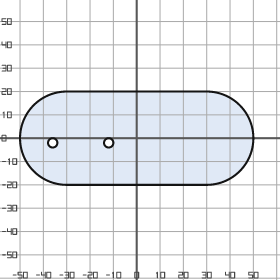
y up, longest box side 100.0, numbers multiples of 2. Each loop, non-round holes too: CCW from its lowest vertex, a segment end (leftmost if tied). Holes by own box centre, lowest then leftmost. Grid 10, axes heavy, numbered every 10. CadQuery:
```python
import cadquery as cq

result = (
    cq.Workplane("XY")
    .moveTo(-30.0, -20.0)
    .lineTo(30.0, -20.0)
    .threePointArc((50.0, 0.0), (30.0, 20.0))
    .lineTo(-30.0, 20.0)
    .threePointArc((-50.0, 0.0), (-30.0, -20.0))
    .close()
    .moveTo(-36.0, -2.0)
    .circle(2.0)
    .moveTo(-12.0, -2.0)
    .circle(2.0)
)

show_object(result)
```